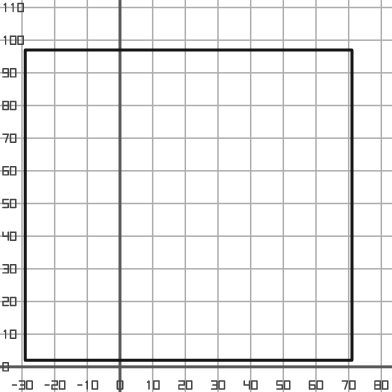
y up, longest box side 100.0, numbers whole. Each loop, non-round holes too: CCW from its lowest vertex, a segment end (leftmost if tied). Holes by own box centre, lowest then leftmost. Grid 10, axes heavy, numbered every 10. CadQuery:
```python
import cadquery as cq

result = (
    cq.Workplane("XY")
    .moveTo(-29.0, 2.0)
    .lineTo(71.0, 2.0)
    .lineTo(71.0, 97.0)
    .lineTo(-29.0, 97.0)
    .close()
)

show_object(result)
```